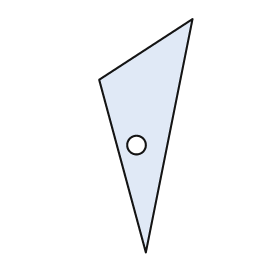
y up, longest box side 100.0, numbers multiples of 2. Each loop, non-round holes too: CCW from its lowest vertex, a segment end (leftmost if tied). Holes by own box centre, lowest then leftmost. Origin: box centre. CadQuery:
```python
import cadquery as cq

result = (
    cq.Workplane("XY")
    .moveTo(0.0, -50.0)
    .lineTo(20.0, 50.0)
    .lineTo(-20.0, 24.0)
    .close()
    .moveTo(-4.0, -4.0)
    .circle(4.0)
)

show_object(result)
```